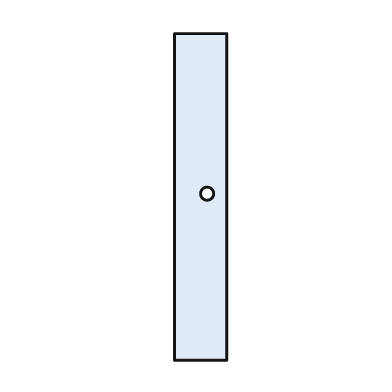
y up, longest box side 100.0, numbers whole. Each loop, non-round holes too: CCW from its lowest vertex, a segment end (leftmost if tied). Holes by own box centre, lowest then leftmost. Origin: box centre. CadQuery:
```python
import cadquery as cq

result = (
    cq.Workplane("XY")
    .moveTo(-8.0, -50.0)
    .lineTo(8.0, -50.0)
    .lineTo(8.0, 50.0)
    .lineTo(-8.0, 50.0)
    .close()
    .moveTo(2.0, 1.0)
    .circle(2.0)
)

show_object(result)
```